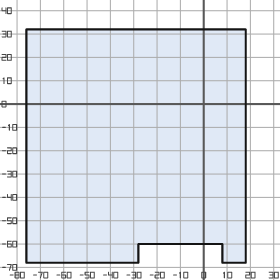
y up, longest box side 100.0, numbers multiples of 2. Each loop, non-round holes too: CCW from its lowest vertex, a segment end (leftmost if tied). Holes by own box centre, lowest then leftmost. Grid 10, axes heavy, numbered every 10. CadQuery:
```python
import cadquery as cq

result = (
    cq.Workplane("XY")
    .moveTo(-76.0, -68.0)
    .lineTo(-28.0, -68.0)
    .lineTo(-28.0, -60.0)
    .lineTo(8.0, -60.0)
    .lineTo(8.0, -68.0)
    .lineTo(18.0, -68.0)
    .lineTo(18.0, 32.0)
    .lineTo(-76.0, 32.0)
    .close()
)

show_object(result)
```